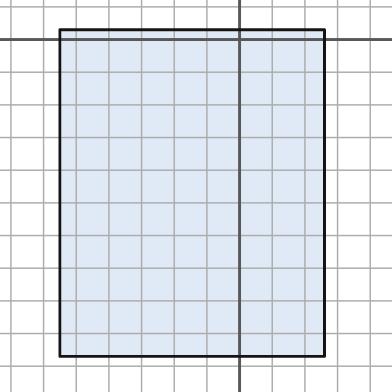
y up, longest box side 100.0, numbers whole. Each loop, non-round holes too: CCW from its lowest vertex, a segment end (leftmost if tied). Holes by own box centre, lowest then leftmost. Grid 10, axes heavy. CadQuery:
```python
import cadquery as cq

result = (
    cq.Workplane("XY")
    .moveTo(-55.0, -97.0)
    .lineTo(26.0, -97.0)
    .lineTo(26.0, 3.0)
    .lineTo(-55.0, 3.0)
    .close()
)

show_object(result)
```